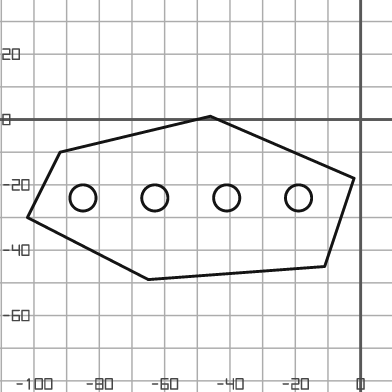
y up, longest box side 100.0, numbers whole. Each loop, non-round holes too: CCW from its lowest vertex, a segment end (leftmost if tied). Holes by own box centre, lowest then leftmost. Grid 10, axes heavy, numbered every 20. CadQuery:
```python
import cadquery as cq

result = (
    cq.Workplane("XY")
    .moveTo(-65.0, -49.0)
    .lineTo(-11.0, -45.0)
    .lineTo(-2.0, -18.0)
    .lineTo(-46.0, 1.0)
    .lineTo(-92.0, -10.0)
    .lineTo(-102.0, -30.0)
    .close()
    .moveTo(-85.0, -24.0)
    .circle(4.0)
    .moveTo(-63.0, -24.0)
    .circle(4.0)
    .moveTo(-41.0, -24.0)
    .circle(4.0)
    .moveTo(-19.0, -24.0)
    .circle(4.0)
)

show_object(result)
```